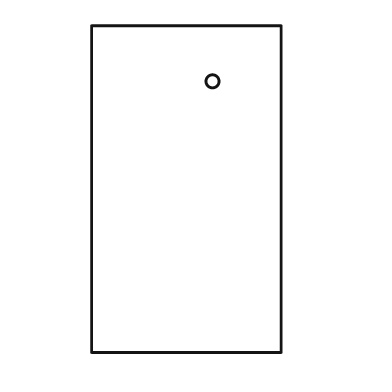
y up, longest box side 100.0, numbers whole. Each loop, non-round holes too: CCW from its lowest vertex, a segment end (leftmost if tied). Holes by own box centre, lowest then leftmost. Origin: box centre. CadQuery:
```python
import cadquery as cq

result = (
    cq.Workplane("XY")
    .moveTo(-29.0, -50.0)
    .lineTo(29.0, -50.0)
    .lineTo(29.0, 50.0)
    .lineTo(-29.0, 50.0)
    .close()
    .moveTo(8.0, 33.0)
    .circle(2.0)
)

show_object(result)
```